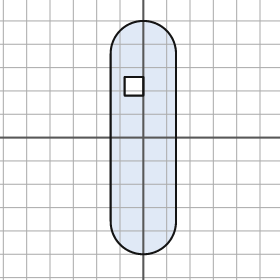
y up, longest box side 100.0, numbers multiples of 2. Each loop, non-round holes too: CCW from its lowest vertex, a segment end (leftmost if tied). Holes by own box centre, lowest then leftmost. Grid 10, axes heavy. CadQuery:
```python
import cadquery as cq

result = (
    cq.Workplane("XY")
    .moveTo(-14.0, -36.0)
    .threePointArc((0.0, -50.0), (14.0, -36.0))
    .lineTo(14.0, 36.0)
    .threePointArc((0.0, 50.0), (-14.0, 36.0))
    .close()
    .moveTo(-8.0, 18.0)
    .lineTo(0.0, 18.0)
    .lineTo(0.0, 26.0)
    .lineTo(-8.0, 26.0)
    .close()
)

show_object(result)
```